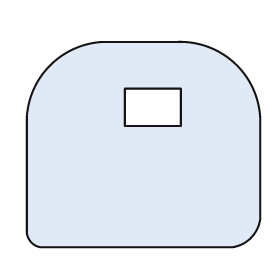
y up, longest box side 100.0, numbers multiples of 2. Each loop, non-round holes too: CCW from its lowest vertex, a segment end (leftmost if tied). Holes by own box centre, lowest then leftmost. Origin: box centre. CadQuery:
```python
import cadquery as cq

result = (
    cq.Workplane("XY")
    .moveTo(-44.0, -44.0)
    .lineTo(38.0, -44.0)
    .threePointArc((46.0, -40.0), (50.0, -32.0))
    .lineTo(50.0, 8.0)
    .threePointArc((40.0, 34.0), (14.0, 44.0))
    .lineTo(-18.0, 44.0)
    .threePointArc((-40.0, 34.0), (-50.0, 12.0))
    .lineTo(-50.0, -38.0)
    .threePointArc((-48.0, -42.0), (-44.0, -44.0))
    .close()
    .moveTo(-8.0, 8.0)
    .lineTo(16.0, 8.0)
    .lineTo(16.0, 24.0)
    .lineTo(-8.0, 24.0)
    .close()
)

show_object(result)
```